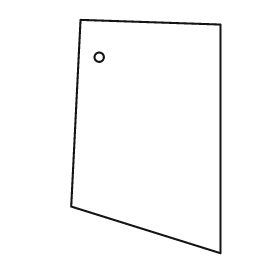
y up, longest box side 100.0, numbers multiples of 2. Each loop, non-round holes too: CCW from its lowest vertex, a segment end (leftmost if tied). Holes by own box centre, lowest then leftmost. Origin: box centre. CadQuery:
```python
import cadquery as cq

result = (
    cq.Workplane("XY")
    .moveTo(32.0, -50.0)
    .lineTo(32.0, 48.0)
    .lineTo(-28.0, 50.0)
    .lineTo(-32.0, -30.0)
    .close()
    .moveTo(-20.0, 34.0)
    .circle(2.0)
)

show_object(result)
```